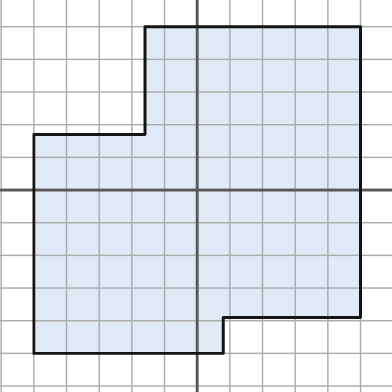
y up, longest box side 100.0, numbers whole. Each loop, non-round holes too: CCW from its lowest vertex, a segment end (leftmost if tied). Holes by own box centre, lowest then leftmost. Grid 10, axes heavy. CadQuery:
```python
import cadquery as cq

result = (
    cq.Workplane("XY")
    .moveTo(-50.0, -50.0)
    .lineTo(8.0, -50.0)
    .lineTo(8.0, -39.0)
    .lineTo(50.0, -39.0)
    .lineTo(50.0, 50.0)
    .lineTo(-16.0, 50.0)
    .lineTo(-16.0, 17.0)
    .lineTo(-50.0, 17.0)
    .close()
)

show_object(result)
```